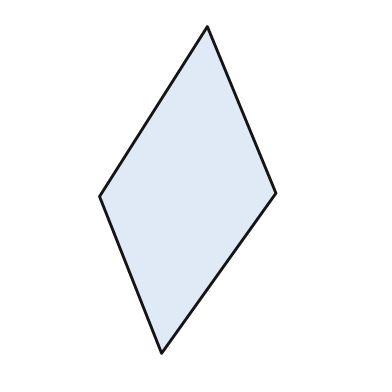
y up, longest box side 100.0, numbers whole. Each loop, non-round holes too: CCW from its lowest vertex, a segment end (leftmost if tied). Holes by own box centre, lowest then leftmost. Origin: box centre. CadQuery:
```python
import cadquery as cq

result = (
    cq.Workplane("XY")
    .moveTo(-8.0, -50.0)
    .lineTo(27.0, -1.0)
    .lineTo(6.0, 50.0)
    .lineTo(-27.0, -2.0)
    .close()
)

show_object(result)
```